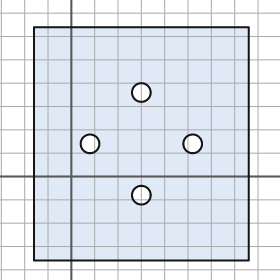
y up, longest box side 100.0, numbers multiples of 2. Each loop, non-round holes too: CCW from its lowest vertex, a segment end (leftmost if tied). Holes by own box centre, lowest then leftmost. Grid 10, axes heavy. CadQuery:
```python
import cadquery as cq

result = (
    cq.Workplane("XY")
    .moveTo(-16.0, -36.0)
    .lineTo(76.0, -36.0)
    .lineTo(76.0, 64.0)
    .lineTo(-16.0, 64.0)
    .close()
    .moveTo(30.0, -8.0)
    .circle(4.0)
    .moveTo(8.0, 14.0)
    .circle(4.0)
    .moveTo(52.0, 14.0)
    .circle(4.0)
    .moveTo(30.0, 36.0)
    .circle(4.0)
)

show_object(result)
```